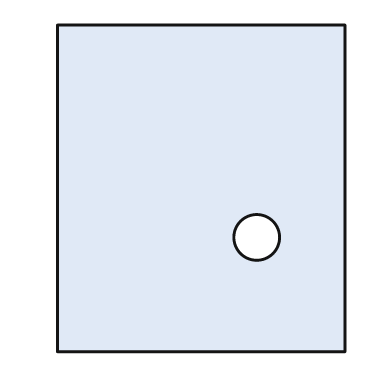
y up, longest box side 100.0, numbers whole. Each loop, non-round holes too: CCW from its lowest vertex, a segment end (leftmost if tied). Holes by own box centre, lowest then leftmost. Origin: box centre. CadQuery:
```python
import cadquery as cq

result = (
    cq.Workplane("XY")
    .moveTo(-44.0, -50.0)
    .lineTo(44.0, -50.0)
    .lineTo(44.0, 50.0)
    .lineTo(-44.0, 50.0)
    .close()
    .moveTo(17.0, -15.0)
    .circle(7.0)
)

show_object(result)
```